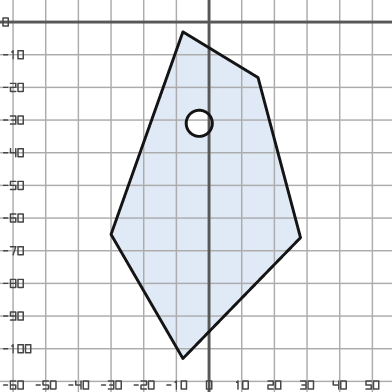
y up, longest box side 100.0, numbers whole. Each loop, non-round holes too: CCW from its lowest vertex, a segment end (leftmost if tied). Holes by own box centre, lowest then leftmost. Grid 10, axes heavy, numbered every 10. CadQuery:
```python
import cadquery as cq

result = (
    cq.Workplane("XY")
    .moveTo(-8.0, -103.0)
    .lineTo(28.0, -66.0)
    .lineTo(15.0, -17.0)
    .lineTo(-8.0, -3.0)
    .lineTo(-30.0, -65.0)
    .close()
    .moveTo(-3.0, -31.0)
    .circle(4.0)
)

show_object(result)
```